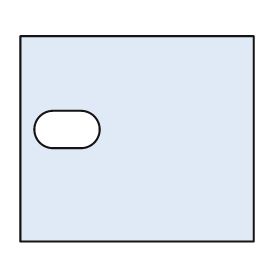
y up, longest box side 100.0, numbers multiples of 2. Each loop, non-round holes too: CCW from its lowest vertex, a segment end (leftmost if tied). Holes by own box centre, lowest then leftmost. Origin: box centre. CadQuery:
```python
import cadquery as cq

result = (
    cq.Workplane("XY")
    .moveTo(-50.0, -44.0)
    .lineTo(50.0, -44.0)
    .lineTo(50.0, 44.0)
    .lineTo(-50.0, 44.0)
    .close()
    .moveTo(-36.0, -4.0)
    .lineTo(-24.0, -4.0)
    .threePointArc((-16.0, 4.0), (-24.0, 12.0))
    .lineTo(-36.0, 12.0)
    .threePointArc((-44.0, 4.0), (-36.0, -4.0))
    .close()
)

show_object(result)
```